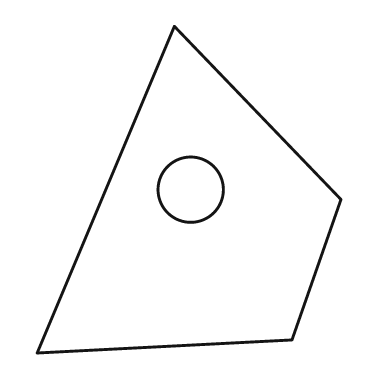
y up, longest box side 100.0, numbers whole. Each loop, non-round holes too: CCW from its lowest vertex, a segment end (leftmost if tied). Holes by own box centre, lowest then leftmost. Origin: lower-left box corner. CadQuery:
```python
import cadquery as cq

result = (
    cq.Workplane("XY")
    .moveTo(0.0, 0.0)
    .lineTo(78.0, 4.0)
    .lineTo(93.0, 47.0)
    .lineTo(42.0, 100.0)
    .close()
    .moveTo(47.0, 50.0)
    .circle(10.0)
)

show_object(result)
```